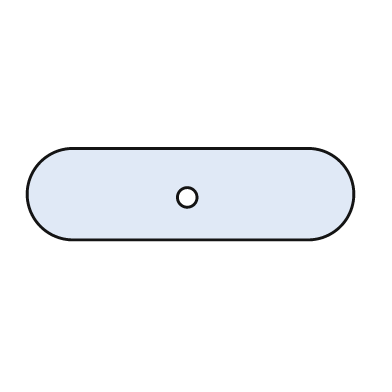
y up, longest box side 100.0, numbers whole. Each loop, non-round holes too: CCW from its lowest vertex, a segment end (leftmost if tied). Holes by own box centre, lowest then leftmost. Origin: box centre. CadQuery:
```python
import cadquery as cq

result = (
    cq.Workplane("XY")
    .moveTo(-36.0, -14.0)
    .lineTo(36.0, -14.0)
    .threePointArc((50.0, 0.0), (36.0, 14.0))
    .lineTo(-36.0, 14.0)
    .threePointArc((-50.0, 0.0), (-36.0, -14.0))
    .close()
    .moveTo(-1.0, -1.0)
    .circle(3.0)
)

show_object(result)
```